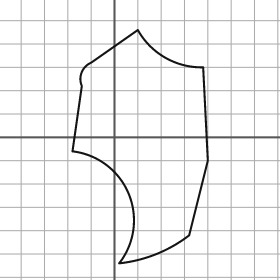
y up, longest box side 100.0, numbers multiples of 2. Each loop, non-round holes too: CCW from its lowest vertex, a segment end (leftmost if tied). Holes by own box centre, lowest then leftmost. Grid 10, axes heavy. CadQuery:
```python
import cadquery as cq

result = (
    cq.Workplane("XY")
    .moveTo(2.0, -54.0)
    .threePointArc((18.0, -50.0), (32.0, -42.0))
    .lineTo(40.0, -10.0)
    .lineTo(38.0, 30.0)
    .threePointArc((22.0, 34.0), (10.0, 46.0))
    .lineTo(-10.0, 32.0)
    .threePointArc((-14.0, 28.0), (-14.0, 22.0))
    .lineTo(-18.0, -6.0)
    .threePointArc((6.0, -24.0), (2.0, -54.0))
    .close()
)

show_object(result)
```